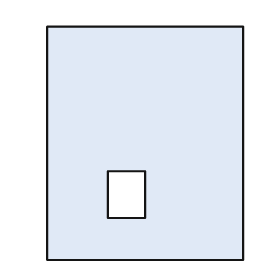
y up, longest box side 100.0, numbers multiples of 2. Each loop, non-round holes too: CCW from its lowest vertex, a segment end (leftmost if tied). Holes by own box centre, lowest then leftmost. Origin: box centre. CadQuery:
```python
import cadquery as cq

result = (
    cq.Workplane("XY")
    .moveTo(-42.0, -50.0)
    .lineTo(42.0, -50.0)
    .lineTo(42.0, 50.0)
    .lineTo(-42.0, 50.0)
    .close()
    .moveTo(-16.0, -32.0)
    .lineTo(0.0, -32.0)
    .lineTo(0.0, -12.0)
    .lineTo(-16.0, -12.0)
    .close()
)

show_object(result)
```